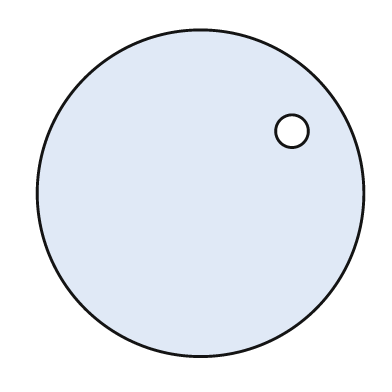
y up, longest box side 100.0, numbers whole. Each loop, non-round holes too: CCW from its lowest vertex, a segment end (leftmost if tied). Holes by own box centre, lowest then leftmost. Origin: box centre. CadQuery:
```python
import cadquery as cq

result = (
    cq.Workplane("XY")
    .moveTo(0.0, 0.0)
    .circle(50.0)
    .moveTo(28.0, 19.0)
    .circle(5.0)
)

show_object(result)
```